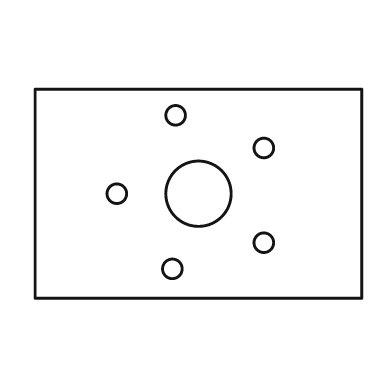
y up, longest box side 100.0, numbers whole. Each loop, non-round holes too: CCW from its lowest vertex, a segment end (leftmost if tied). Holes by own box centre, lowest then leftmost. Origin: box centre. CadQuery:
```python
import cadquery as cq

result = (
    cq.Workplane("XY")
    .moveTo(-50.0, -32.0)
    .lineTo(50.0, -32.0)
    .lineTo(50.0, 32.0)
    .lineTo(-50.0, 32.0)
    .close()
    .moveTo(-8.0, -23.0)
    .circle(3.0)
    .moveTo(20.0, -15.0)
    .circle(3.0)
    .moveTo(-25.0, 0.0)
    .circle(3.0)
    .moveTo(0.0, 0.0)
    .circle(10.0)
    .moveTo(20.0, 14.0)
    .circle(3.0)
    .moveTo(-7.0, 24.0)
    .circle(3.0)
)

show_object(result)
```